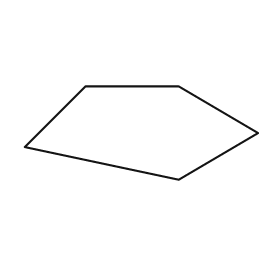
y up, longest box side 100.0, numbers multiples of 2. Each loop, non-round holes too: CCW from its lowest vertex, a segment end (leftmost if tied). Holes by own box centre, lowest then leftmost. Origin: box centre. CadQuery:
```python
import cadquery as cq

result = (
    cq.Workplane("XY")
    .moveTo(16.0, -20.0)
    .lineTo(50.0, 0.0)
    .lineTo(16.0, 20.0)
    .lineTo(-24.0, 20.0)
    .lineTo(-50.0, -6.0)
    .close()
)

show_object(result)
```